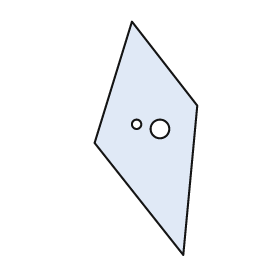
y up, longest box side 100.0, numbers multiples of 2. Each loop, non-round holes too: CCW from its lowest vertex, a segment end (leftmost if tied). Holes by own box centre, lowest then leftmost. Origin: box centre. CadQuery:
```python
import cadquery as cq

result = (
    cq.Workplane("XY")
    .moveTo(16.0, -50.0)
    .lineTo(22.0, 14.0)
    .lineTo(-6.0, 50.0)
    .lineTo(-22.0, -2.0)
    .close()
    .moveTo(6.0, 4.0)
    .circle(4.0)
    .moveTo(-4.0, 6.0)
    .circle(2.0)
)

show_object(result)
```